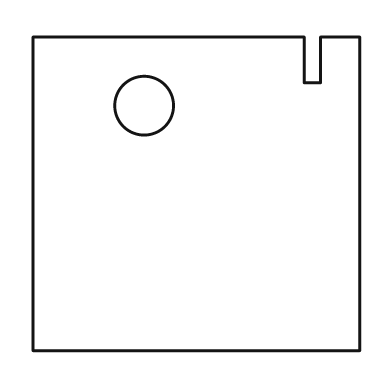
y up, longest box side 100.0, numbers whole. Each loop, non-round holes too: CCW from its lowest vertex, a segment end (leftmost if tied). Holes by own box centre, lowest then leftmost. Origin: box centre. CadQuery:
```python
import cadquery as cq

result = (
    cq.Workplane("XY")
    .moveTo(-50.0, -48.0)
    .lineTo(50.0, -48.0)
    .lineTo(50.0, 48.0)
    .lineTo(38.0, 48.0)
    .lineTo(38.0, 34.0)
    .lineTo(33.0, 34.0)
    .lineTo(33.0, 48.0)
    .lineTo(-50.0, 48.0)
    .close()
    .moveTo(-16.0, 27.0)
    .circle(9.0)
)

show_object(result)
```